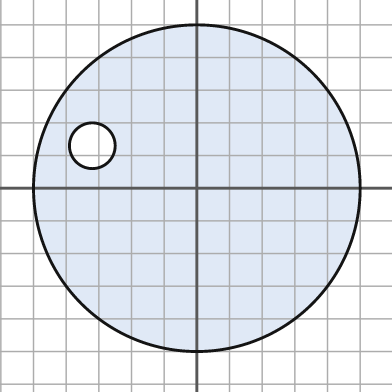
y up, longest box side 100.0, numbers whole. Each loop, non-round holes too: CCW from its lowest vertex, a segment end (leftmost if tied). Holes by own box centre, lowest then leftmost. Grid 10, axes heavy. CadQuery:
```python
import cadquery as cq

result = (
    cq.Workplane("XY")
    .moveTo(0.0, 0.0)
    .circle(50.0)
    .moveTo(-32.0, 13.0)
    .circle(7.0)
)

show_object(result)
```